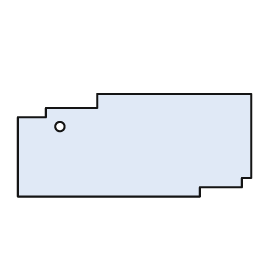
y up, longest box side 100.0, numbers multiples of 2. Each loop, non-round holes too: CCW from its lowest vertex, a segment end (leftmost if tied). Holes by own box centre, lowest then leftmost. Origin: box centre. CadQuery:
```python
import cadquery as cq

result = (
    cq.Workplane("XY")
    .moveTo(-50.0, -22.0)
    .lineTo(28.0, -22.0)
    .lineTo(28.0, -18.0)
    .lineTo(46.0, -18.0)
    .lineTo(46.0, -14.0)
    .lineTo(50.0, -14.0)
    .lineTo(50.0, 22.0)
    .lineTo(-16.0, 22.0)
    .lineTo(-16.0, 16.0)
    .lineTo(-38.0, 16.0)
    .lineTo(-38.0, 12.0)
    .lineTo(-50.0, 12.0)
    .close()
    .moveTo(-32.0, 8.0)
    .circle(2.0)
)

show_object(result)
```